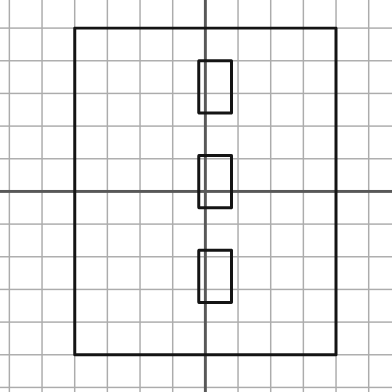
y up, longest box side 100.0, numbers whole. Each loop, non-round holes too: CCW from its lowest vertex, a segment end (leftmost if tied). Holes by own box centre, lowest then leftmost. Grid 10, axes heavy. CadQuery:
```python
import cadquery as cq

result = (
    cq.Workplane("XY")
    .moveTo(-40.0, -50.0)
    .lineTo(40.0, -50.0)
    .lineTo(40.0, 50.0)
    .lineTo(-40.0, 50.0)
    .close()
    .moveTo(-2.0, -34.0)
    .lineTo(8.0, -34.0)
    .lineTo(8.0, -18.0)
    .lineTo(-2.0, -18.0)
    .close()
    .moveTo(-2.0, -5.0)
    .lineTo(8.0, -5.0)
    .lineTo(8.0, 11.0)
    .lineTo(-2.0, 11.0)
    .close()
    .moveTo(-2.0, 24.0)
    .lineTo(8.0, 24.0)
    .lineTo(8.0, 40.0)
    .lineTo(-2.0, 40.0)
    .close()
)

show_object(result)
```